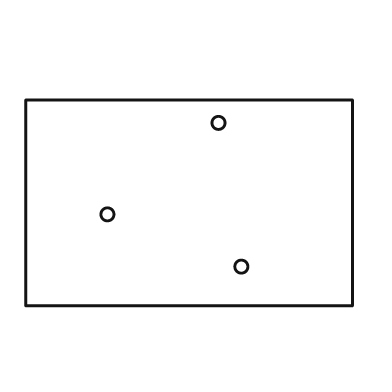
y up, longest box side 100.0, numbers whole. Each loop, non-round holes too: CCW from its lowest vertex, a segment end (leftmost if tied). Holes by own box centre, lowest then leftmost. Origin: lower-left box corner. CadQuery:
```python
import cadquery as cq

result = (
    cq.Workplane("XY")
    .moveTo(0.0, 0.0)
    .lineTo(100.0, 0.0)
    .lineTo(100.0, 63.0)
    .lineTo(0.0, 63.0)
    .close()
    .moveTo(66.0, 12.0)
    .circle(2.0)
    .moveTo(25.0, 28.0)
    .circle(2.0)
    .moveTo(59.0, 56.0)
    .circle(2.0)
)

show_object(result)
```